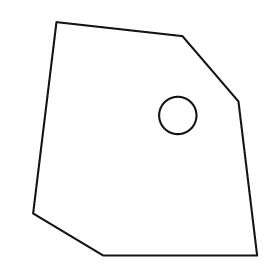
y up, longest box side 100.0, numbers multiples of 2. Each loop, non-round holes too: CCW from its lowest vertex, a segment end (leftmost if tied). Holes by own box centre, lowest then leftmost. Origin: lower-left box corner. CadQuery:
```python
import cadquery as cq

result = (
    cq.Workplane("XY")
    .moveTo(30.0, 0.0)
    .lineTo(96.0, 0.0)
    .lineTo(88.0, 66.0)
    .lineTo(64.0, 94.0)
    .lineTo(10.0, 100.0)
    .lineTo(0.0, 18.0)
    .close()
    .moveTo(62.0, 60.0)
    .circle(8.0)
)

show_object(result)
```